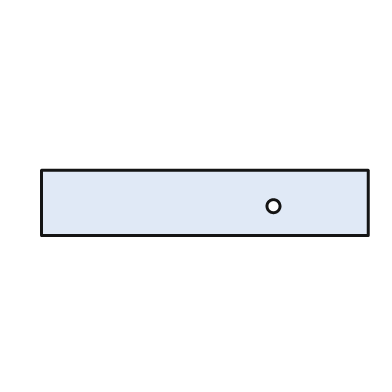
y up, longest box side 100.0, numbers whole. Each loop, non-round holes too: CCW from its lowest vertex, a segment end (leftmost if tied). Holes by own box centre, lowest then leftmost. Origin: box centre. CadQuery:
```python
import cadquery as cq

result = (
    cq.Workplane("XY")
    .moveTo(-50.0, -10.0)
    .lineTo(50.0, -10.0)
    .lineTo(50.0, 10.0)
    .lineTo(-50.0, 10.0)
    .close()
    .moveTo(21.0, -1.0)
    .circle(2.0)
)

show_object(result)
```